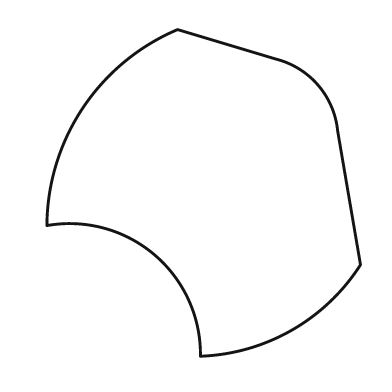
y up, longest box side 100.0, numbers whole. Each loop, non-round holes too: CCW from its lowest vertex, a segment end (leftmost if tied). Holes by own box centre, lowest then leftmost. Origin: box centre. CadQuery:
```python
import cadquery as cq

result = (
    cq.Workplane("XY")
    .moveTo(-1.0, -50.0)
    .threePointArc((27.0, -42.0), (48.0, -22.0))
    .lineTo(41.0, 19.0)
    .threePointArc((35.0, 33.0), (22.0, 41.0))
    .lineTo(-8.0, 50.0)
    .threePointArc((-37.0, 26.0), (-48.0, -10.0))
    .threePointArc((-15.0, -19.0), (-1.0, -50.0))
    .close()
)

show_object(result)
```